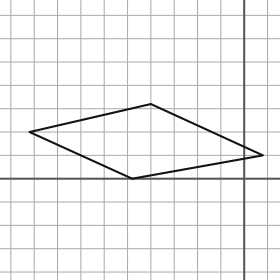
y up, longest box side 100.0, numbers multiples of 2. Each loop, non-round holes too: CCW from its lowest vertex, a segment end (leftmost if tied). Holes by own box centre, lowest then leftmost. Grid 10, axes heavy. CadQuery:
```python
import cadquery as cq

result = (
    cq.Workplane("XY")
    .moveTo(-48.0, 0.0)
    .lineTo(8.0, 10.0)
    .lineTo(-40.0, 32.0)
    .lineTo(-92.0, 20.0)
    .close()
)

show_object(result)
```